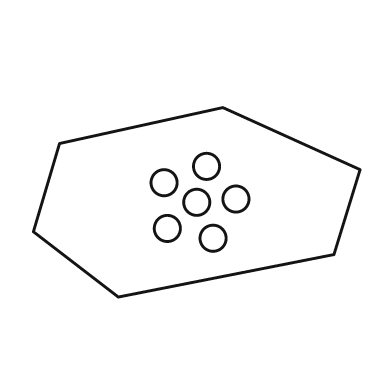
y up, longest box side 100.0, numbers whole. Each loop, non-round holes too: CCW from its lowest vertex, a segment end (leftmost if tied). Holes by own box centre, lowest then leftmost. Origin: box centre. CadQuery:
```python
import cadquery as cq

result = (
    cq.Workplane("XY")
    .moveTo(-24.0, -29.0)
    .lineTo(42.0, -16.0)
    .lineTo(50.0, 10.0)
    .lineTo(8.0, 29.0)
    .lineTo(-42.0, 18.0)
    .lineTo(-50.0, -9.0)
    .close()
    .moveTo(5.0, -11.0)
    .circle(4.0)
    .moveTo(-9.0, -8.0)
    .circle(4.0)
    .moveTo(0.0, 0.0)
    .circle(4.0)
    .moveTo(12.0, 1.0)
    .circle(4.0)
    .moveTo(-10.0, 6.0)
    .circle(4.0)
    .moveTo(3.0, 11.0)
    .circle(4.0)
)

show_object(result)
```